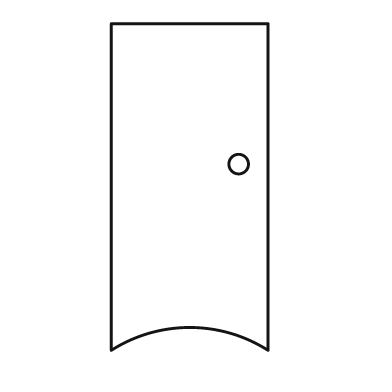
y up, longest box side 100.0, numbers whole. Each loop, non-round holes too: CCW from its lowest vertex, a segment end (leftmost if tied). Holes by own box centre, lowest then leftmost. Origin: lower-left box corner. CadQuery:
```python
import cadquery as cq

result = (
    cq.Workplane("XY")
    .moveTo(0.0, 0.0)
    .threePointArc((24.0, 7.0), (48.0, 0.0))
    .lineTo(48.0, 100.0)
    .lineTo(0.0, 100.0)
    .close()
    .moveTo(39.0, 57.0)
    .circle(3.0)
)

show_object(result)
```